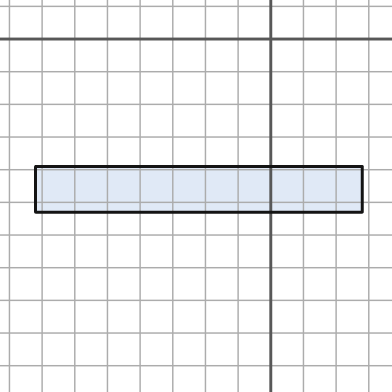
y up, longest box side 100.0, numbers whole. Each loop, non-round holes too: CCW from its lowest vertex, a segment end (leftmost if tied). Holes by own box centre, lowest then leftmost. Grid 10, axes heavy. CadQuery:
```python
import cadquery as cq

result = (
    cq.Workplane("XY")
    .moveTo(-72.0, -53.0)
    .lineTo(28.0, -53.0)
    .lineTo(28.0, -39.0)
    .lineTo(-72.0, -39.0)
    .close()
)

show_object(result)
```